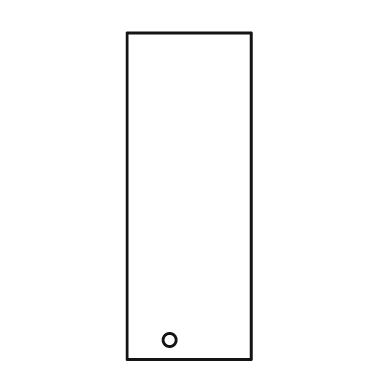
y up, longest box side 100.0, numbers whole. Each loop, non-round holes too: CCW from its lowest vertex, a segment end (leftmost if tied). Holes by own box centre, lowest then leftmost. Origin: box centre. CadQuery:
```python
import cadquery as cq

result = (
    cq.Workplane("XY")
    .moveTo(-19.0, -50.0)
    .lineTo(19.0, -50.0)
    .lineTo(19.0, 50.0)
    .lineTo(-19.0, 50.0)
    .close()
    .moveTo(-6.0, -44.0)
    .circle(2.0)
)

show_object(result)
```